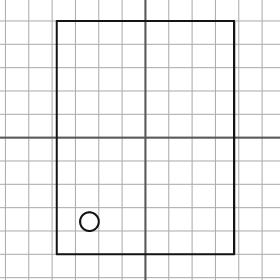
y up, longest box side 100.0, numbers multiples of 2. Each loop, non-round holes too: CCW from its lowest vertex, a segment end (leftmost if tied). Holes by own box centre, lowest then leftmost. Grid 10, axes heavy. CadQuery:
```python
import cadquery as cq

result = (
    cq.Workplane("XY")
    .moveTo(-38.0, -50.0)
    .lineTo(38.0, -50.0)
    .lineTo(38.0, 50.0)
    .lineTo(-38.0, 50.0)
    .close()
    .moveTo(-24.0, -36.0)
    .circle(4.0)
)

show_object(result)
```